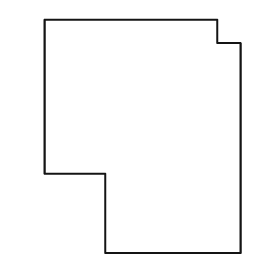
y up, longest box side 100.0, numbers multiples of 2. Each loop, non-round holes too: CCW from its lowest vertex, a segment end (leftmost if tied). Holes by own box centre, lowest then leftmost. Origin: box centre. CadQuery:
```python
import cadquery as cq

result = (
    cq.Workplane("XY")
    .moveTo(-16.0, -50.0)
    .lineTo(42.0, -50.0)
    .lineTo(42.0, 40.0)
    .lineTo(32.0, 40.0)
    .lineTo(32.0, 50.0)
    .lineTo(-42.0, 50.0)
    .lineTo(-42.0, -16.0)
    .lineTo(-16.0, -16.0)
    .close()
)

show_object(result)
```